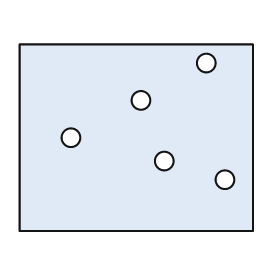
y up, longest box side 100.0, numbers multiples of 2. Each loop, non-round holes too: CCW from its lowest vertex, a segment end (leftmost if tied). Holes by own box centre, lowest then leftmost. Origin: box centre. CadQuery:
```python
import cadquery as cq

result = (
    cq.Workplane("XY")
    .moveTo(-50.0, -40.0)
    .lineTo(50.0, -40.0)
    .lineTo(50.0, 40.0)
    .lineTo(-50.0, 40.0)
    .close()
    .moveTo(38.0, -18.0)
    .circle(4.0)
    .moveTo(12.0, -10.0)
    .circle(4.0)
    .moveTo(-28.0, 0.0)
    .circle(4.0)
    .moveTo(2.0, 16.0)
    .circle(4.0)
    .moveTo(30.0, 32.0)
    .circle(4.0)
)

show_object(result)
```